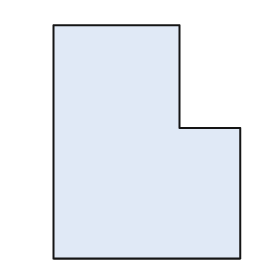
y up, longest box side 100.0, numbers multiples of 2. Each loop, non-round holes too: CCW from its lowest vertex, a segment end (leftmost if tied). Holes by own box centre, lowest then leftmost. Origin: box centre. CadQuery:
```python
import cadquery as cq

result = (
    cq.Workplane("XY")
    .moveTo(-40.0, -50.0)
    .lineTo(40.0, -50.0)
    .lineTo(40.0, 6.0)
    .lineTo(14.0, 6.0)
    .lineTo(14.0, 50.0)
    .lineTo(-40.0, 50.0)
    .close()
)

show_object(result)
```